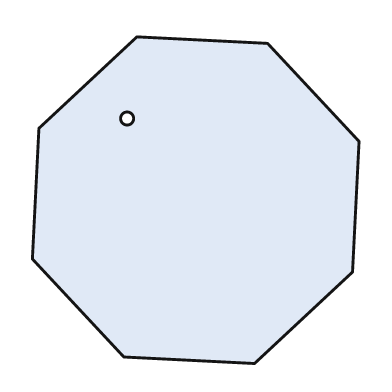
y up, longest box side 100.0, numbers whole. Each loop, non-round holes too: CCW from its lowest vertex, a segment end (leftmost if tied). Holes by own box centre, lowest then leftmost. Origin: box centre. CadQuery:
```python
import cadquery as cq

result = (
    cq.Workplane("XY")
    .moveTo(18.0, -50.0)
    .lineTo(48.0, -22.0)
    .lineTo(50.0, 18.0)
    .lineTo(22.0, 48.0)
    .lineTo(-18.0, 50.0)
    .lineTo(-48.0, 22.0)
    .lineTo(-50.0, -18.0)
    .lineTo(-22.0, -48.0)
    .close()
    .moveTo(-21.0, 25.0)
    .circle(2.0)
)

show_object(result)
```